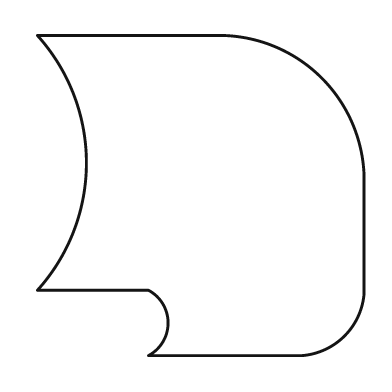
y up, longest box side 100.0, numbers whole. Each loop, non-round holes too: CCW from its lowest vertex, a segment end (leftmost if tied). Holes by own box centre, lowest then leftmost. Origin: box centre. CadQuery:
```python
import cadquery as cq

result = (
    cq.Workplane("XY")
    .moveTo(-16.0, -49.0)
    .lineTo(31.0, -49.0)
    .threePointArc((44.0, -43.0), (50.0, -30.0))
    .lineTo(50.0, 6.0)
    .threePointArc((37.0, 36.0), (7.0, 49.0))
    .lineTo(-50.0, 49.0)
    .threePointArc((-35.0, 10.0), (-50.0, -29.0))
    .lineTo(-16.0, -29.0)
    .threePointArc((-10.0, -39.0), (-16.0, -49.0))
    .close()
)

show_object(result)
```